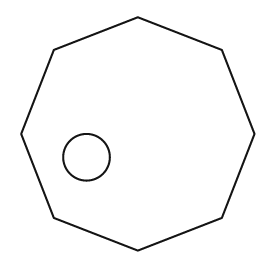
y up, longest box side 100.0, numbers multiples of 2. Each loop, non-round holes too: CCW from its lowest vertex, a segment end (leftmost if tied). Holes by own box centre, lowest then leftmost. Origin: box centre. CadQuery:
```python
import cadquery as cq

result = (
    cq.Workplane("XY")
    .moveTo(0.0, -50.0)
    .lineTo(36.0, -36.0)
    .lineTo(50.0, 0.0)
    .lineTo(36.0, 36.0)
    .lineTo(0.0, 50.0)
    .lineTo(-36.0, 36.0)
    .lineTo(-50.0, 0.0)
    .lineTo(-36.0, -36.0)
    .close()
    .moveTo(-22.0, -10.0)
    .circle(10.0)
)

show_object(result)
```